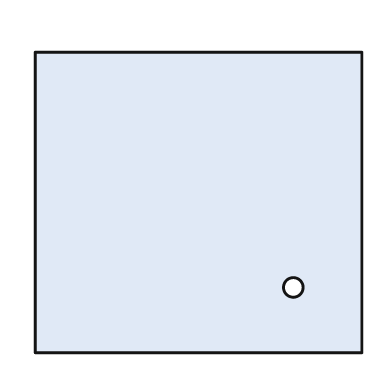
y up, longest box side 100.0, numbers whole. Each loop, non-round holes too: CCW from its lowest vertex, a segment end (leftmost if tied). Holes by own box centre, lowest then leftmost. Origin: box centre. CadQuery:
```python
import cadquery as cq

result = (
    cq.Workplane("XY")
    .moveTo(-50.0, -46.0)
    .lineTo(50.0, -46.0)
    .lineTo(50.0, 46.0)
    .lineTo(-50.0, 46.0)
    .close()
    .moveTo(29.0, -26.0)
    .circle(3.0)
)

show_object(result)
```